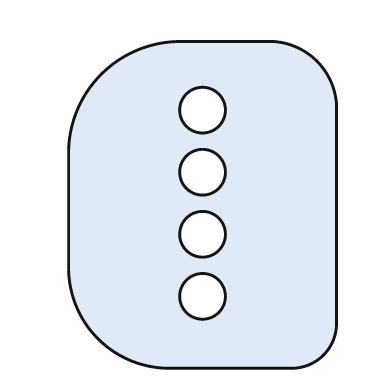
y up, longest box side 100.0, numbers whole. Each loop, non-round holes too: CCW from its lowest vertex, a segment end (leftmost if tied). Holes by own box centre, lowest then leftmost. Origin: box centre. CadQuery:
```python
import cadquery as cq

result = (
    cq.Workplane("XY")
    .moveTo(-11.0, -50.0)
    .lineTo(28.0, -50.0)
    .threePointArc((37.0, -46.0), (41.0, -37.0))
    .lineTo(41.0, 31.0)
    .threePointArc((35.0, 44.0), (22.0, 50.0))
    .lineTo(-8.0, 50.0)
    .threePointArc((-31.0, 40.0), (-41.0, 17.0))
    .lineTo(-41.0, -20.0)
    .threePointArc((-32.0, -41.0), (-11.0, -50.0))
    .close()
    .moveTo(0.0, -28.0)
    .circle(7.0)
    .moveTo(0.0, -9.0)
    .circle(7.0)
    .moveTo(0.0, 10.0)
    .circle(7.0)
    .moveTo(0.0, 29.0)
    .circle(7.0)
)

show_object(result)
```